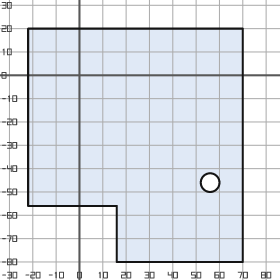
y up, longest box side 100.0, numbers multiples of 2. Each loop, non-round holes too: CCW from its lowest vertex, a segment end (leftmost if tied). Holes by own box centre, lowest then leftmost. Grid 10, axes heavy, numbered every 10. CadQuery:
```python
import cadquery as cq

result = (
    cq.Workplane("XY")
    .moveTo(16.0, -80.0)
    .lineTo(70.0, -80.0)
    .lineTo(70.0, 20.0)
    .lineTo(-22.0, 20.0)
    .lineTo(-22.0, -56.0)
    .lineTo(16.0, -56.0)
    .close()
    .moveTo(56.0, -46.0)
    .circle(4.0)
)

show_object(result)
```